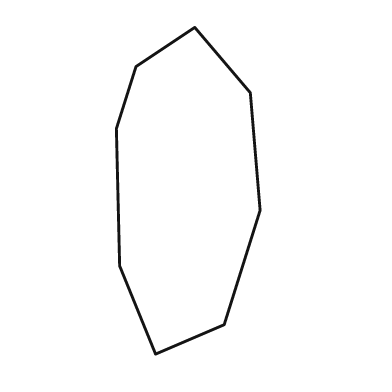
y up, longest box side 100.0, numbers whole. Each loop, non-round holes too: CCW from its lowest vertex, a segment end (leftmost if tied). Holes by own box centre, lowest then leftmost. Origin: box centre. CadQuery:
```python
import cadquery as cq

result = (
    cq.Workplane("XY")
    .moveTo(-10.0, -50.0)
    .lineTo(11.0, -41.0)
    .lineTo(22.0, -6.0)
    .lineTo(19.0, 30.0)
    .lineTo(2.0, 50.0)
    .lineTo(-16.0, 38.0)
    .lineTo(-22.0, 19.0)
    .lineTo(-21.0, -23.0)
    .close()
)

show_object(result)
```